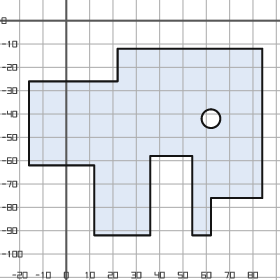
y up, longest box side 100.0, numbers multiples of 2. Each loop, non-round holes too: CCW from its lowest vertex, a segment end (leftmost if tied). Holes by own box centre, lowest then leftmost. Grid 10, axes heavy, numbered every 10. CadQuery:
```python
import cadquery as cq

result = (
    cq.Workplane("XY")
    .moveTo(12.0, -92.0)
    .lineTo(36.0, -92.0)
    .lineTo(36.0, -58.0)
    .lineTo(54.0, -58.0)
    .lineTo(54.0, -92.0)
    .lineTo(62.0, -92.0)
    .lineTo(62.0, -76.0)
    .lineTo(84.0, -76.0)
    .lineTo(84.0, -12.0)
    .lineTo(22.0, -12.0)
    .lineTo(22.0, -26.0)
    .lineTo(-16.0, -26.0)
    .lineTo(-16.0, -62.0)
    .lineTo(12.0, -62.0)
    .close()
    .moveTo(62.0, -42.0)
    .circle(4.0)
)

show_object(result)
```